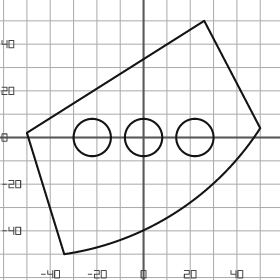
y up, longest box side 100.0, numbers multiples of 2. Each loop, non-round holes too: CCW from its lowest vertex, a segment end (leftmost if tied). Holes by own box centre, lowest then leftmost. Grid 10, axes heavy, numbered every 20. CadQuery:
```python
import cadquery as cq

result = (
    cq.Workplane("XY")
    .moveTo(-34.0, -50.0)
    .threePointArc((14.0, -32.0), (50.0, 4.0))
    .lineTo(26.0, 50.0)
    .lineTo(-50.0, 2.0)
    .close()
    .moveTo(-22.0, 0.0)
    .circle(8.0)
    .moveTo(0.0, 0.0)
    .circle(8.0)
    .moveTo(22.0, 0.0)
    .circle(8.0)
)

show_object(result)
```